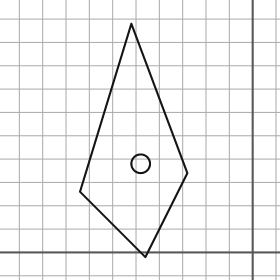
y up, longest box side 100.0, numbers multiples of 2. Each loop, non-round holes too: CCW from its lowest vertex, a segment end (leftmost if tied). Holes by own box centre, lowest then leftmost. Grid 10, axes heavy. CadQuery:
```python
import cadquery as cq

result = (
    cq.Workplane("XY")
    .moveTo(-46.0, -2.0)
    .lineTo(-28.0, 34.0)
    .lineTo(-52.0, 98.0)
    .lineTo(-74.0, 26.0)
    .close()
    .moveTo(-48.0, 38.0)
    .circle(4.0)
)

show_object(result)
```